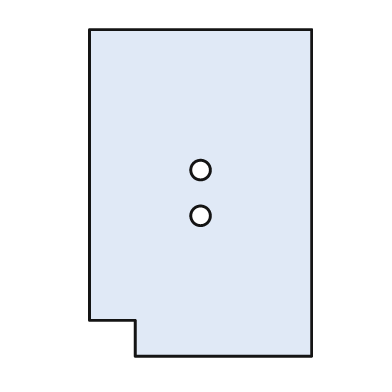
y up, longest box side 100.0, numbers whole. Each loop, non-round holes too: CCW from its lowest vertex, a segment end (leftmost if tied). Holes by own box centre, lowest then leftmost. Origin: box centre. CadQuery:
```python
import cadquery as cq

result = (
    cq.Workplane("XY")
    .moveTo(-20.0, -50.0)
    .lineTo(34.0, -50.0)
    .lineTo(34.0, 50.0)
    .lineTo(-34.0, 50.0)
    .lineTo(-34.0, -39.0)
    .lineTo(-20.0, -39.0)
    .close()
    .moveTo(0.0, -7.0)
    .circle(3.0)
    .moveTo(0.0, 7.0)
    .circle(3.0)
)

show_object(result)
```